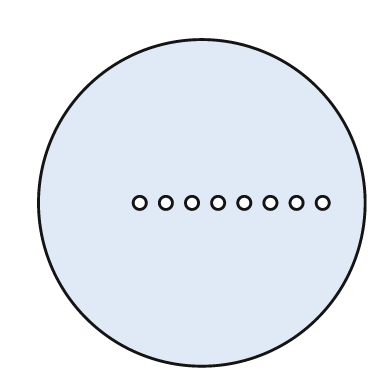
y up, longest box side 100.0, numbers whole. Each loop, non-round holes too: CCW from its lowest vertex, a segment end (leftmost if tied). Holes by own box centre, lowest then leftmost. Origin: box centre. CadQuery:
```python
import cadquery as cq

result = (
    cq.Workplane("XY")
    .moveTo(0.0, 0.0)
    .circle(50.0)
    .moveTo(-19.0, 0.0)
    .circle(2.0)
    .moveTo(-11.0, 0.0)
    .circle(2.0)
    .moveTo(-3.0, 0.0)
    .circle(2.0)
    .moveTo(5.0, 0.0)
    .circle(2.0)
    .moveTo(13.0, 0.0)
    .circle(2.0)
    .moveTo(21.0, 0.0)
    .circle(2.0)
    .moveTo(29.0, 0.0)
    .circle(2.0)
    .moveTo(37.0, 0.0)
    .circle(2.0)
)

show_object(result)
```